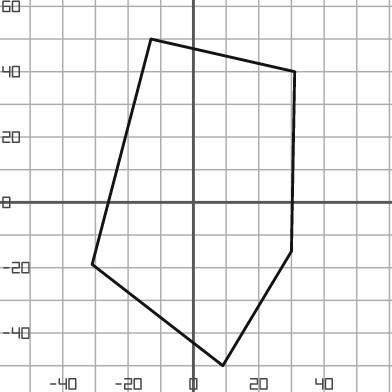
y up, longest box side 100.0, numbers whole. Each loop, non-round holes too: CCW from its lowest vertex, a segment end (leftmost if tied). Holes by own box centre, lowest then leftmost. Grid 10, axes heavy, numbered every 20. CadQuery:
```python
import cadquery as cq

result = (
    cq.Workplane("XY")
    .moveTo(9.0, -50.0)
    .lineTo(30.0, -15.0)
    .lineTo(31.0, 40.0)
    .lineTo(-13.0, 50.0)
    .lineTo(-31.0, -19.0)
    .close()
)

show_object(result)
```